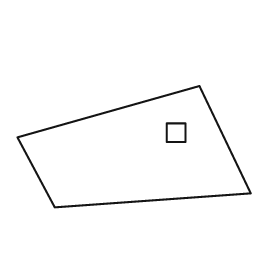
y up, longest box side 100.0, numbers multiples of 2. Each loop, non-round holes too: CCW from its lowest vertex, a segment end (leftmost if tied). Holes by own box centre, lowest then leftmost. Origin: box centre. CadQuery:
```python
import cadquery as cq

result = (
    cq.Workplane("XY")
    .moveTo(-34.0, -26.0)
    .lineTo(50.0, -20.0)
    .lineTo(28.0, 26.0)
    .lineTo(-50.0, 4.0)
    .close()
    .moveTo(14.0, 2.0)
    .lineTo(22.0, 2.0)
    .lineTo(22.0, 10.0)
    .lineTo(14.0, 10.0)
    .close()
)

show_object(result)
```